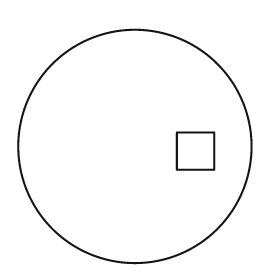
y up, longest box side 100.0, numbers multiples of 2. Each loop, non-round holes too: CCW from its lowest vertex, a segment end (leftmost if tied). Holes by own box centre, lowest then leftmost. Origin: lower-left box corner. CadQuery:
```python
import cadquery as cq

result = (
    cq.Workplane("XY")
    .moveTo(50.0, 50.0)
    .circle(50.0)
    .moveTo(68.0, 40.0)
    .lineTo(84.0, 40.0)
    .lineTo(84.0, 56.0)
    .lineTo(68.0, 56.0)
    .close()
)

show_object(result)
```